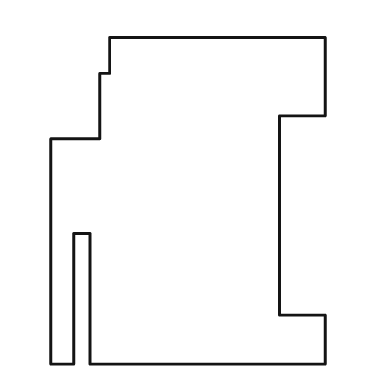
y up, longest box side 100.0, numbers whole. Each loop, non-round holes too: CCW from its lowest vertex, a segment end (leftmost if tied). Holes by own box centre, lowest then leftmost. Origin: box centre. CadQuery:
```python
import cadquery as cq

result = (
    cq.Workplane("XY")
    .moveTo(-42.0, -50.0)
    .lineTo(-35.0, -50.0)
    .lineTo(-35.0, -10.0)
    .lineTo(-30.0, -10.0)
    .lineTo(-30.0, -50.0)
    .lineTo(42.0, -50.0)
    .lineTo(42.0, -35.0)
    .lineTo(28.0, -35.0)
    .lineTo(28.0, 26.0)
    .lineTo(42.0, 26.0)
    .lineTo(42.0, 50.0)
    .lineTo(-24.0, 50.0)
    .lineTo(-24.0, 39.0)
    .lineTo(-27.0, 39.0)
    .lineTo(-27.0, 19.0)
    .lineTo(-42.0, 19.0)
    .close()
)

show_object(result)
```